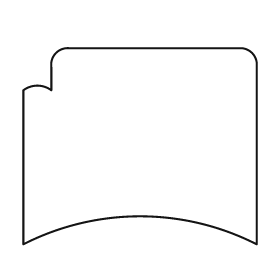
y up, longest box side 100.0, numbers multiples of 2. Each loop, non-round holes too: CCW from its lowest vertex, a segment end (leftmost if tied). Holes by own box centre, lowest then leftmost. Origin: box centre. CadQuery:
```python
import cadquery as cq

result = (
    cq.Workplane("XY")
    .moveTo(-50.0, -42.0)
    .threePointArc((0.0, -30.0), (50.0, -42.0))
    .lineTo(50.0, 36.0)
    .threePointArc((48.0, 40.0), (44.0, 42.0))
    .lineTo(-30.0, 42.0)
    .threePointArc((-36.0, 40.0), (-38.0, 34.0))
    .lineTo(-38.0, 24.0)
    .threePointArc((-44.0, 26.0), (-50.0, 24.0))
    .close()
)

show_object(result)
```